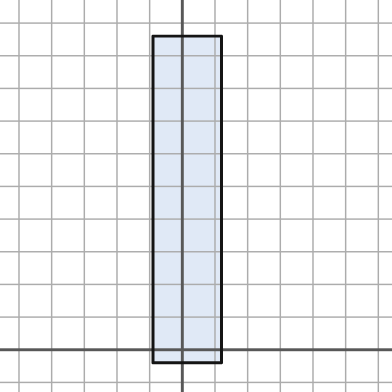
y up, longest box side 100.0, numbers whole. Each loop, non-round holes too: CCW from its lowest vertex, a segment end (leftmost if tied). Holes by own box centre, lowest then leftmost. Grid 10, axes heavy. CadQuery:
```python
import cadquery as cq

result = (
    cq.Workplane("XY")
    .moveTo(-9.0, -4.0)
    .lineTo(12.0, -4.0)
    .lineTo(12.0, 96.0)
    .lineTo(-9.0, 96.0)
    .close()
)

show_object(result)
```